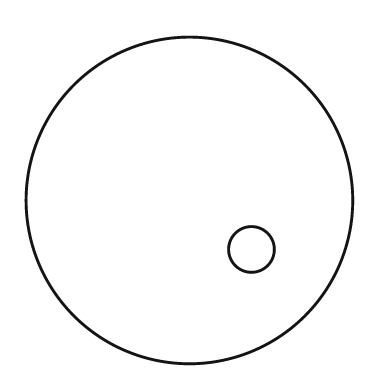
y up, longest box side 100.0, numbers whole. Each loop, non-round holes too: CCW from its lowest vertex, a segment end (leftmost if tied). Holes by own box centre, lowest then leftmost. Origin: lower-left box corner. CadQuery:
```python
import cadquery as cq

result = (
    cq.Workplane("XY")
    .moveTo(50.0, 50.0)
    .circle(50.0)
    .moveTo(69.0, 35.0)
    .circle(7.0)
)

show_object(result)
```